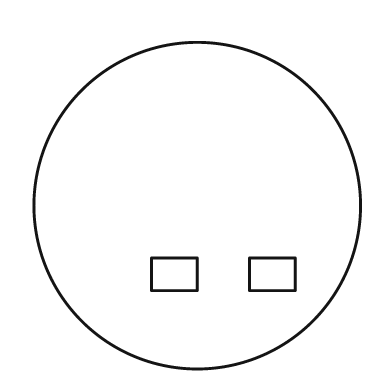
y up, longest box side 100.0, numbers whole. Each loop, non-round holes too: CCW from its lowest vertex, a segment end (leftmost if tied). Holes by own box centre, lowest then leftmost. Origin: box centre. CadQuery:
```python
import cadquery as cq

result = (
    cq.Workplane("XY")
    .moveTo(0.0, 0.0)
    .circle(50.0)
    .moveTo(-14.0, -26.0)
    .lineTo(0.0, -26.0)
    .lineTo(0.0, -16.0)
    .lineTo(-14.0, -16.0)
    .close()
    .moveTo(16.0, -26.0)
    .lineTo(30.0, -26.0)
    .lineTo(30.0, -16.0)
    .lineTo(16.0, -16.0)
    .close()
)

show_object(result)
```